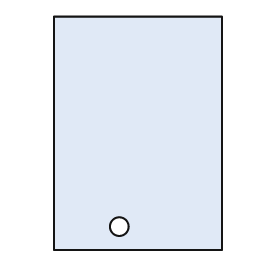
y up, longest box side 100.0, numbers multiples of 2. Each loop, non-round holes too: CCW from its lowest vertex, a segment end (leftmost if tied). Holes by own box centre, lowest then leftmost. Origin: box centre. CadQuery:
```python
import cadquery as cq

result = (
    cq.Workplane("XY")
    .moveTo(-36.0, -50.0)
    .lineTo(36.0, -50.0)
    .lineTo(36.0, 50.0)
    .lineTo(-36.0, 50.0)
    .close()
    .moveTo(-8.0, -40.0)
    .circle(4.0)
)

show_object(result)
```